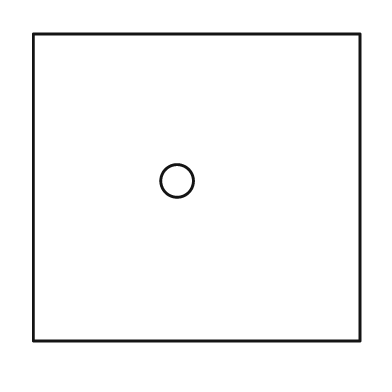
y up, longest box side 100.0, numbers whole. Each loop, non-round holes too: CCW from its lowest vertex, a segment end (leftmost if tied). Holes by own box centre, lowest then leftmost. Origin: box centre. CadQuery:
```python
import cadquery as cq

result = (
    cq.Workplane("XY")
    .moveTo(-50.0, -47.0)
    .lineTo(50.0, -47.0)
    .lineTo(50.0, 47.0)
    .lineTo(-50.0, 47.0)
    .close()
    .moveTo(-6.0, 2.0)
    .circle(5.0)
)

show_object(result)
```